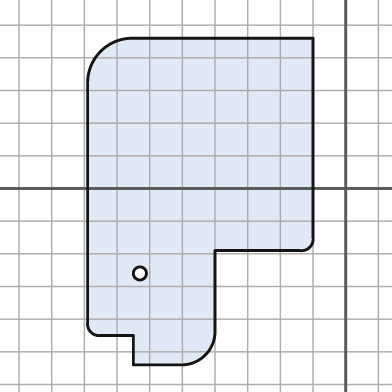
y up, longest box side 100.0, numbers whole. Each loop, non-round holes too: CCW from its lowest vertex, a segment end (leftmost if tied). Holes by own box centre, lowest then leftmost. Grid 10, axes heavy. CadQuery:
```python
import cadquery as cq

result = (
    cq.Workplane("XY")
    .moveTo(-65.0, -54.0)
    .lineTo(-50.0, -54.0)
    .threePointArc((-43.0, -51.0), (-40.0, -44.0))
    .lineTo(-40.0, -19.0)
    .lineTo(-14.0, -19.0)
    .threePointArc((-11.0, -18.0), (-10.0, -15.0))
    .lineTo(-10.0, 46.0)
    .lineTo(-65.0, 46.0)
    .threePointArc((-75.0, 42.0), (-79.0, 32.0))
    .lineTo(-79.0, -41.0)
    .threePointArc((-78.0, -44.0), (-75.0, -45.0))
    .lineTo(-65.0, -45.0)
    .close()
    .moveTo(-63.0, -26.0)
    .circle(2.0)
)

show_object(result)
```